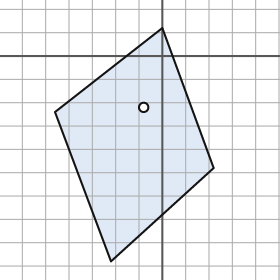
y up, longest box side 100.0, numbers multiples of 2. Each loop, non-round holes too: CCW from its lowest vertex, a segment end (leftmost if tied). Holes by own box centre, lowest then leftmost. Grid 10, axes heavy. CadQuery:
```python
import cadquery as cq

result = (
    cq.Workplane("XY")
    .moveTo(-22.0, -88.0)
    .lineTo(22.0, -48.0)
    .lineTo(0.0, 12.0)
    .lineTo(-46.0, -24.0)
    .close()
    .moveTo(-8.0, -22.0)
    .circle(2.0)
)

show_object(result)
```